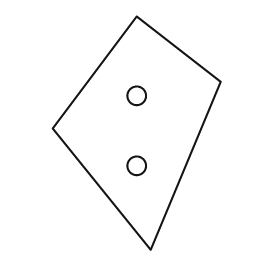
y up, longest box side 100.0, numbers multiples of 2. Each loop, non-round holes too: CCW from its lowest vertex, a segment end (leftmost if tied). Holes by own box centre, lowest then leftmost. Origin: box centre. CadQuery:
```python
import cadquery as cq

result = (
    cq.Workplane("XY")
    .moveTo(6.0, -50.0)
    .lineTo(36.0, 22.0)
    .lineTo(0.0, 50.0)
    .lineTo(-36.0, 2.0)
    .close()
    .moveTo(0.0, -14.0)
    .circle(4.0)
    .moveTo(0.0, 16.0)
    .circle(4.0)
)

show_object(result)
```